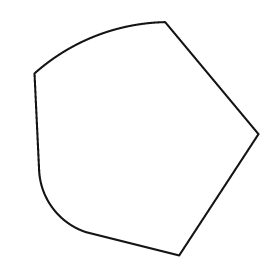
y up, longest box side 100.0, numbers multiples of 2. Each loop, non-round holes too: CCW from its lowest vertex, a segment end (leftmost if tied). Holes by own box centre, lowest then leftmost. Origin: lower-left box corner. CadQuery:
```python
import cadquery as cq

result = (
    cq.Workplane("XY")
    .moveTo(62.0, 0.0)
    .lineTo(96.0, 52.0)
    .lineTo(56.0, 100.0)
    .threePointArc((26.0, 94.0), (0.0, 78.0))
    .lineTo(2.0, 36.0)
    .threePointArc((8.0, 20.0), (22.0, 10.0))
    .close()
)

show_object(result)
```